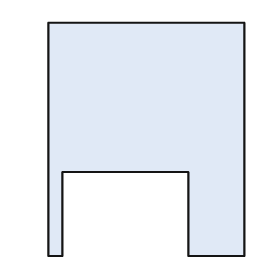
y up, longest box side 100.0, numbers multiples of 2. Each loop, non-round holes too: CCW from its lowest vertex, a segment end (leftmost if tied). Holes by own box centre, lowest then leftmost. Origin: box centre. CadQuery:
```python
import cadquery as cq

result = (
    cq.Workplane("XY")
    .moveTo(-42.0, -50.0)
    .lineTo(-36.0, -50.0)
    .lineTo(-36.0, -14.0)
    .lineTo(18.0, -14.0)
    .lineTo(18.0, -50.0)
    .lineTo(42.0, -50.0)
    .lineTo(42.0, 50.0)
    .lineTo(-42.0, 50.0)
    .close()
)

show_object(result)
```